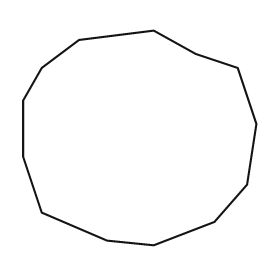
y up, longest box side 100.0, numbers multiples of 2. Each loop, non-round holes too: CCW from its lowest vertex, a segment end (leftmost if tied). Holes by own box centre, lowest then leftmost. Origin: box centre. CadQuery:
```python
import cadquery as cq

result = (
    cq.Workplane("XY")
    .moveTo(6.0, -46.0)
    .lineTo(32.0, -36.0)
    .lineTo(46.0, -20.0)
    .lineTo(50.0, 6.0)
    .lineTo(42.0, 30.0)
    .lineTo(24.0, 36.0)
    .lineTo(6.0, 46.0)
    .lineTo(-26.0, 42.0)
    .lineTo(-42.0, 30.0)
    .lineTo(-50.0, 16.0)
    .lineTo(-50.0, -8.0)
    .lineTo(-42.0, -32.0)
    .lineTo(-14.0, -44.0)
    .close()
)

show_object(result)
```